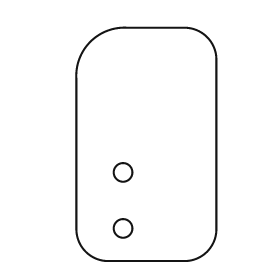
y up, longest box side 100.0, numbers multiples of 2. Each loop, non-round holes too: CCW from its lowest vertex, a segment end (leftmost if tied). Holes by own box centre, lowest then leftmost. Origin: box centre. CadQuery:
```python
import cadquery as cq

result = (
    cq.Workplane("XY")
    .moveTo(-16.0, -50.0)
    .lineTo(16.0, -50.0)
    .threePointArc((26.0, -46.0), (30.0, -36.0))
    .lineTo(30.0, 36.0)
    .threePointArc((26.0, 46.0), (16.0, 50.0))
    .lineTo(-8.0, 50.0)
    .threePointArc((-24.0, 44.0), (-30.0, 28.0))
    .lineTo(-30.0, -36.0)
    .threePointArc((-26.0, -46.0), (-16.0, -50.0))
    .close()
    .moveTo(-10.0, -36.0)
    .circle(4.0)
    .moveTo(-10.0, -12.0)
    .circle(4.0)
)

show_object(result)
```